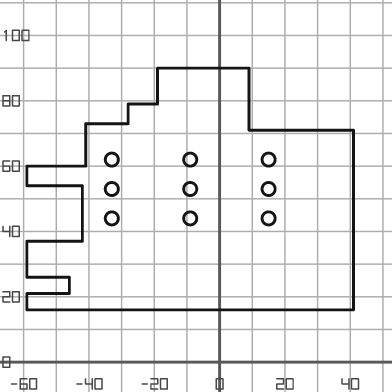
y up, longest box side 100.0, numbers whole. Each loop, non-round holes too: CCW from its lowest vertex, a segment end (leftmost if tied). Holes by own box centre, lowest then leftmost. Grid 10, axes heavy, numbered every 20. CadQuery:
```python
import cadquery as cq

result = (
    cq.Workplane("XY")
    .moveTo(-59.0, 16.0)
    .lineTo(41.0, 16.0)
    .lineTo(41.0, 71.0)
    .lineTo(9.0, 71.0)
    .lineTo(9.0, 90.0)
    .lineTo(-19.0, 90.0)
    .lineTo(-19.0, 79.0)
    .lineTo(-28.0, 79.0)
    .lineTo(-28.0, 73.0)
    .lineTo(-41.0, 73.0)
    .lineTo(-41.0, 60.0)
    .lineTo(-59.0, 60.0)
    .lineTo(-59.0, 54.0)
    .lineTo(-42.0, 54.0)
    .lineTo(-42.0, 37.0)
    .lineTo(-59.0, 37.0)
    .lineTo(-59.0, 26.0)
    .lineTo(-46.0, 26.0)
    .lineTo(-46.0, 21.0)
    .lineTo(-59.0, 21.0)
    .close()
    .moveTo(-33.0, 44.0)
    .circle(2.0)
    .moveTo(-9.0, 44.0)
    .circle(2.0)
    .moveTo(15.0, 44.0)
    .circle(2.0)
    .moveTo(-33.0, 53.0)
    .circle(2.0)
    .moveTo(-9.0, 53.0)
    .circle(2.0)
    .moveTo(15.0, 53.0)
    .circle(2.0)
    .moveTo(-33.0, 62.0)
    .circle(2.0)
    .moveTo(-9.0, 62.0)
    .circle(2.0)
    .moveTo(15.0, 62.0)
    .circle(2.0)
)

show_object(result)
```